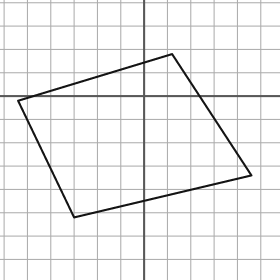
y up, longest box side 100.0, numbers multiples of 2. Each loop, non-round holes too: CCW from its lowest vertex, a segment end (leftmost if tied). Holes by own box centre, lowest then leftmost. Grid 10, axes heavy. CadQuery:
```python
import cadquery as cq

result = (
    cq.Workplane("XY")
    .moveTo(-30.0, -52.0)
    .lineTo(46.0, -34.0)
    .lineTo(12.0, 18.0)
    .lineTo(-54.0, -2.0)
    .close()
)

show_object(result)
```